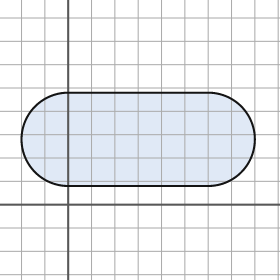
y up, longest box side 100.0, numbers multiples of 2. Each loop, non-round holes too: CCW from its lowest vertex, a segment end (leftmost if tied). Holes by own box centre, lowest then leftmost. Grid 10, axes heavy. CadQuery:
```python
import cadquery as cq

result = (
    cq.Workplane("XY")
    .moveTo(0.0, 8.0)
    .lineTo(60.0, 8.0)
    .threePointArc((80.0, 28.0), (60.0, 48.0))
    .lineTo(0.0, 48.0)
    .threePointArc((-20.0, 28.0), (0.0, 8.0))
    .close()
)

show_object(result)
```